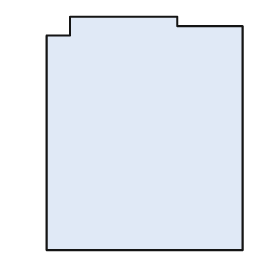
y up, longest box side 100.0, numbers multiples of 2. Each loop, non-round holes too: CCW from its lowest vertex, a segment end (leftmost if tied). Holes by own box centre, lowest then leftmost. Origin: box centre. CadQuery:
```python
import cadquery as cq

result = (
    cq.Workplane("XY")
    .moveTo(-42.0, -50.0)
    .lineTo(42.0, -50.0)
    .lineTo(42.0, 46.0)
    .lineTo(14.0, 46.0)
    .lineTo(14.0, 50.0)
    .lineTo(-32.0, 50.0)
    .lineTo(-32.0, 42.0)
    .lineTo(-42.0, 42.0)
    .close()
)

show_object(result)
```